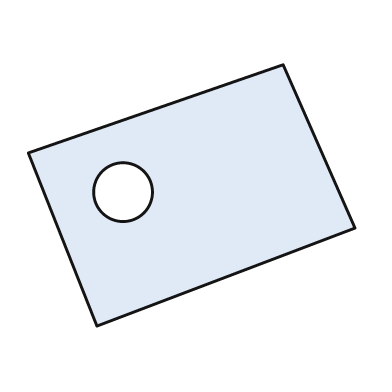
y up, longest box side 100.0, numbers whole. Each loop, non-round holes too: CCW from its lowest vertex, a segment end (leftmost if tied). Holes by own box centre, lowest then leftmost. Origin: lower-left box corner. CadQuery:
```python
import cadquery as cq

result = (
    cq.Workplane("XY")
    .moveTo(21.0, 0.0)
    .lineTo(100.0, 30.0)
    .lineTo(78.0, 80.0)
    .lineTo(0.0, 53.0)
    .close()
    .moveTo(29.0, 41.0)
    .circle(9.0)
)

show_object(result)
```